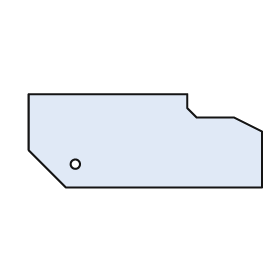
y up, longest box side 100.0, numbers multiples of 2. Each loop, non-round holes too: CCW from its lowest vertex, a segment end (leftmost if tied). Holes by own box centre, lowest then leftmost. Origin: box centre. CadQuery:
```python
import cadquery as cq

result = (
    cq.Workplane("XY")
    .moveTo(-34.0, -20.0)
    .lineTo(50.0, -20.0)
    .lineTo(50.0, 4.0)
    .lineTo(38.0, 10.0)
    .lineTo(22.0, 10.0)
    .lineTo(18.0, 14.0)
    .lineTo(18.0, 20.0)
    .lineTo(-50.0, 20.0)
    .lineTo(-50.0, -4.0)
    .close()
    .moveTo(-30.0, -10.0)
    .circle(2.0)
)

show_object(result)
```